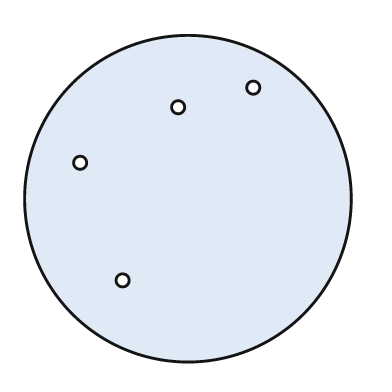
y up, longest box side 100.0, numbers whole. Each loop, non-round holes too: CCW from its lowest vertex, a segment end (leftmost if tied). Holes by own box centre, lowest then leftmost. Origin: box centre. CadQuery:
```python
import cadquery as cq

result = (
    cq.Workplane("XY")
    .moveTo(0.0, 0.0)
    .circle(50.0)
    .moveTo(-20.0, -25.0)
    .circle(2.0)
    .moveTo(-33.0, 11.0)
    .circle(2.0)
    .moveTo(-3.0, 28.0)
    .circle(2.0)
    .moveTo(20.0, 34.0)
    .circle(2.0)
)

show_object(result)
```